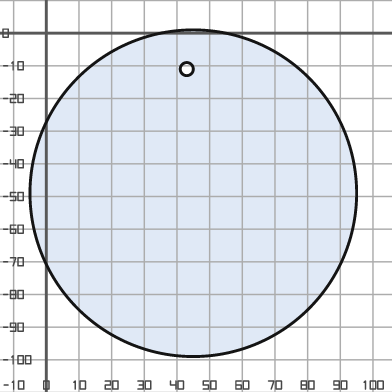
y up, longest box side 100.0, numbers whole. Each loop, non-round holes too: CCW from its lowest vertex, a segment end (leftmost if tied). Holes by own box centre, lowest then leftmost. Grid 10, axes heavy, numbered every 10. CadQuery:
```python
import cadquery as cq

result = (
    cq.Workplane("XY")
    .moveTo(45.0, -49.0)
    .circle(50.0)
    .moveTo(43.0, -11.0)
    .circle(2.0)
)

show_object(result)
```